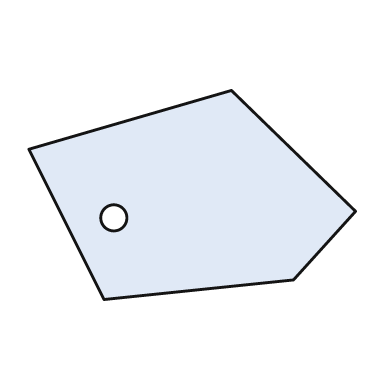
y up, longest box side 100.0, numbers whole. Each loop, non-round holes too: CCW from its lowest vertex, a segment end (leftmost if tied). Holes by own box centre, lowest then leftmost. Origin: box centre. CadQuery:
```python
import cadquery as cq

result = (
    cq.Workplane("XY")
    .moveTo(-27.0, -32.0)
    .lineTo(31.0, -26.0)
    .lineTo(50.0, -5.0)
    .lineTo(12.0, 32.0)
    .lineTo(-50.0, 14.0)
    .close()
    .moveTo(-24.0, -7.0)
    .circle(4.0)
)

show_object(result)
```